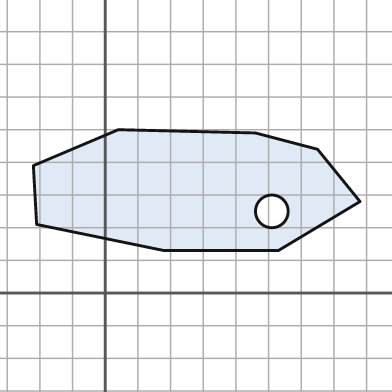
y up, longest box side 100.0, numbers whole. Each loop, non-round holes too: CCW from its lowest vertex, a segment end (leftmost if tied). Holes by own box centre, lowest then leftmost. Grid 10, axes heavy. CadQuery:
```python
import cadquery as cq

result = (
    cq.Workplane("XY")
    .moveTo(18.0, 13.0)
    .lineTo(53.0, 13.0)
    .lineTo(78.0, 28.0)
    .lineTo(65.0, 44.0)
    .lineTo(46.0, 49.0)
    .lineTo(4.0, 50.0)
    .lineTo(-22.0, 39.0)
    .lineTo(-21.0, 21.0)
    .close()
    .moveTo(51.0, 25.0)
    .circle(5.0)
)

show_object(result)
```